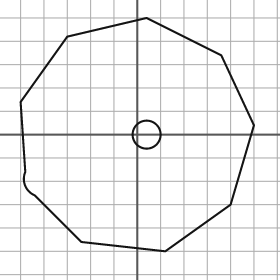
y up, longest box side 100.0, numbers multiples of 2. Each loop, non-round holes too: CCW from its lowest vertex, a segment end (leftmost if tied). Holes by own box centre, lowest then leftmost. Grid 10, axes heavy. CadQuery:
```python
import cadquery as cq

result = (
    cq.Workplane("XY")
    .moveTo(12.0, -50.0)
    .lineTo(40.0, -30.0)
    .lineTo(50.0, 4.0)
    .lineTo(36.0, 34.0)
    .lineTo(4.0, 50.0)
    .lineTo(-30.0, 42.0)
    .lineTo(-50.0, 14.0)
    .lineTo(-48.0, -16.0)
    .threePointArc((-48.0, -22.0), (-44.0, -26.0))
    .lineTo(-24.0, -46.0)
    .close()
    .moveTo(4.0, 0.0)
    .circle(6.0)
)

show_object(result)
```